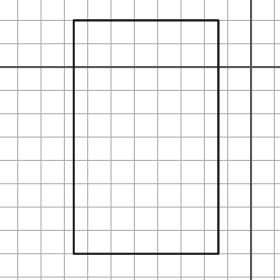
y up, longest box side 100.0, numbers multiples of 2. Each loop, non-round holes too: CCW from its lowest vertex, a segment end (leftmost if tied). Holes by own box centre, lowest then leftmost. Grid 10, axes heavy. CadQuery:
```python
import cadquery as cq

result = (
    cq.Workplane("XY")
    .moveTo(-76.0, -80.0)
    .lineTo(-14.0, -80.0)
    .lineTo(-14.0, 20.0)
    .lineTo(-76.0, 20.0)
    .close()
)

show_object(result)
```